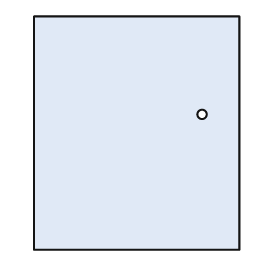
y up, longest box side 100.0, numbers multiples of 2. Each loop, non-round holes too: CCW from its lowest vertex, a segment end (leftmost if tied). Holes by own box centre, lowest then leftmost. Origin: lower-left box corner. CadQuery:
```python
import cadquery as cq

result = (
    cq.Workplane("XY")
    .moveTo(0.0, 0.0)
    .lineTo(88.0, 0.0)
    .lineTo(88.0, 100.0)
    .lineTo(0.0, 100.0)
    .close()
    .moveTo(72.0, 58.0)
    .circle(2.0)
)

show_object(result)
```